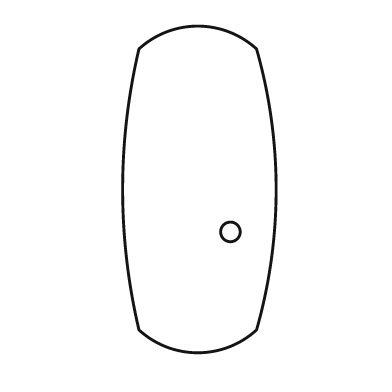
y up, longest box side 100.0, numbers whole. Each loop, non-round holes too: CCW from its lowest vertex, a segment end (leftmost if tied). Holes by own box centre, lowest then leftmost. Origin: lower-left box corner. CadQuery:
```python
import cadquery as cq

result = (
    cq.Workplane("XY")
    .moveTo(5.0, 7.0)
    .threePointArc((23.0, 0.0), (41.0, 7.0))
    .threePointArc((47.0, 50.0), (41.0, 93.0))
    .threePointArc((23.0, 100.0), (5.0, 93.0))
    .threePointArc((0.0, 50.0), (5.0, 7.0))
    .close()
    .moveTo(33.0, 37.0)
    .circle(3.0)
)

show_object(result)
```